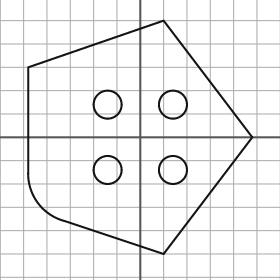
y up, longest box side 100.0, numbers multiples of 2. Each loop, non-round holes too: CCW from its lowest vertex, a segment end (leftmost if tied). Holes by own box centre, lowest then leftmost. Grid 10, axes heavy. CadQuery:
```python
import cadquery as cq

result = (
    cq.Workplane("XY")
    .moveTo(10.0, -50.0)
    .lineTo(48.0, 0.0)
    .lineTo(10.0, 50.0)
    .lineTo(-48.0, 30.0)
    .lineTo(-48.0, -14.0)
    .threePointArc((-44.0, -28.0), (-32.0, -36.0))
    .close()
    .moveTo(-14.0, -14.0)
    .circle(6.0)
    .moveTo(14.0, -14.0)
    .circle(6.0)
    .moveTo(-14.0, 14.0)
    .circle(6.0)
    .moveTo(14.0, 14.0)
    .circle(6.0)
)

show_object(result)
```